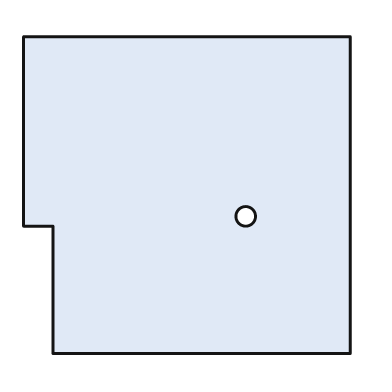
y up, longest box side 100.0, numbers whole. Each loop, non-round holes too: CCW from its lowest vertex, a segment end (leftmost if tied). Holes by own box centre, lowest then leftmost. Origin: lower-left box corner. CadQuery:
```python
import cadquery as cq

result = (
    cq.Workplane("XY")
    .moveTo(9.0, 0.0)
    .lineTo(100.0, 0.0)
    .lineTo(100.0, 97.0)
    .lineTo(0.0, 97.0)
    .lineTo(0.0, 39.0)
    .lineTo(9.0, 39.0)
    .close()
    .moveTo(68.0, 42.0)
    .circle(3.0)
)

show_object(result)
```